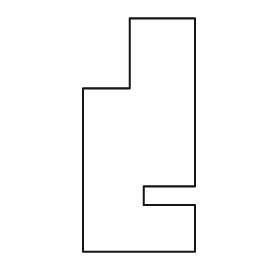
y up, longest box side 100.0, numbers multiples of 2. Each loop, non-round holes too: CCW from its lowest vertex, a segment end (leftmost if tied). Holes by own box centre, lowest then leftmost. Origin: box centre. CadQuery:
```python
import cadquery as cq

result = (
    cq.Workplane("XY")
    .moveTo(-24.0, -50.0)
    .lineTo(24.0, -50.0)
    .lineTo(24.0, -30.0)
    .lineTo(2.0, -30.0)
    .lineTo(2.0, -22.0)
    .lineTo(24.0, -22.0)
    .lineTo(24.0, 50.0)
    .lineTo(-4.0, 50.0)
    .lineTo(-4.0, 20.0)
    .lineTo(-24.0, 20.0)
    .close()
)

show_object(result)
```